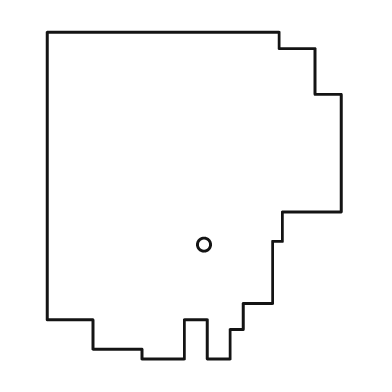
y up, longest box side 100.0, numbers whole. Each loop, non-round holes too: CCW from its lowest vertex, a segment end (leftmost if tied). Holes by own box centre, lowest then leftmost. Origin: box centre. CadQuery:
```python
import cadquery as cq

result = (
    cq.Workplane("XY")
    .moveTo(-16.0, -50.0)
    .lineTo(-3.0, -50.0)
    .lineTo(-3.0, -38.0)
    .lineTo(4.0, -38.0)
    .lineTo(4.0, -50.0)
    .lineTo(11.0, -50.0)
    .lineTo(11.0, -41.0)
    .lineTo(15.0, -41.0)
    .lineTo(15.0, -33.0)
    .lineTo(24.0, -33.0)
    .lineTo(24.0, -14.0)
    .lineTo(27.0, -14.0)
    .lineTo(27.0, -5.0)
    .lineTo(45.0, -5.0)
    .lineTo(45.0, 31.0)
    .lineTo(37.0, 31.0)
    .lineTo(37.0, 45.0)
    .lineTo(26.0, 45.0)
    .lineTo(26.0, 50.0)
    .lineTo(-45.0, 50.0)
    .lineTo(-45.0, -38.0)
    .lineTo(-31.0, -38.0)
    .lineTo(-31.0, -47.0)
    .lineTo(-16.0, -47.0)
    .close()
    .moveTo(3.0, -15.0)
    .circle(2.0)
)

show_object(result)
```